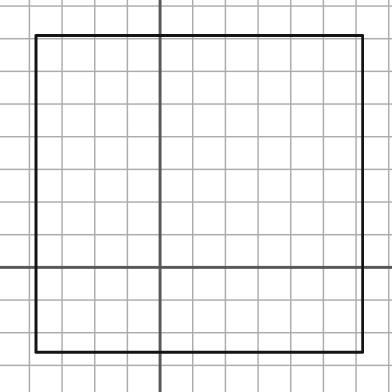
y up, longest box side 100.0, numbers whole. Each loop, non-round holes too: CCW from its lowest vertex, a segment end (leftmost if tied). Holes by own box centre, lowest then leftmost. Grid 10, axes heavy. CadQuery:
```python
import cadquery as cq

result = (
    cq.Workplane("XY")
    .moveTo(-38.0, -26.0)
    .lineTo(62.0, -26.0)
    .lineTo(62.0, 71.0)
    .lineTo(-38.0, 71.0)
    .close()
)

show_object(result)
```